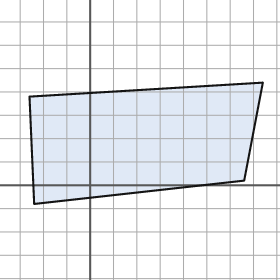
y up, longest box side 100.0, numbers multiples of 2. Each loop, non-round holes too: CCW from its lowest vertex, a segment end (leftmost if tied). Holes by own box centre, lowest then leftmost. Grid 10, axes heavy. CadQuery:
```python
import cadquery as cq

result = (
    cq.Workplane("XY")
    .moveTo(-24.0, -8.0)
    .lineTo(66.0, 2.0)
    .lineTo(74.0, 44.0)
    .lineTo(-26.0, 38.0)
    .close()
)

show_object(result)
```